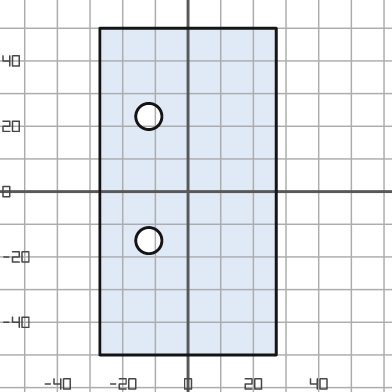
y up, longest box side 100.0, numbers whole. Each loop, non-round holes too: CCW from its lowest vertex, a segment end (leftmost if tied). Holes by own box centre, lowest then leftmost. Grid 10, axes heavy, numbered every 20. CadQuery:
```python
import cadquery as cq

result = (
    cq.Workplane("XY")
    .moveTo(-27.0, -50.0)
    .lineTo(27.0, -50.0)
    .lineTo(27.0, 50.0)
    .lineTo(-27.0, 50.0)
    .close()
    .moveTo(-12.0, -15.0)
    .circle(4.0)
    .moveTo(-12.0, 23.0)
    .circle(4.0)
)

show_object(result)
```